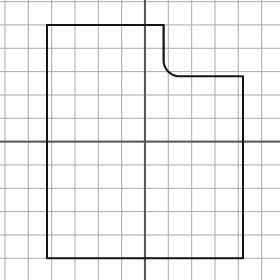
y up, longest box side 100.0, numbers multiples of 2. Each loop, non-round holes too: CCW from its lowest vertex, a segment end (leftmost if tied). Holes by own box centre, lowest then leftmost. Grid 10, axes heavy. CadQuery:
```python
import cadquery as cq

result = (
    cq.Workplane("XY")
    .moveTo(-42.0, -50.0)
    .lineTo(42.0, -50.0)
    .lineTo(42.0, 28.0)
    .lineTo(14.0, 28.0)
    .threePointArc((10.0, 30.0), (8.0, 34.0))
    .lineTo(8.0, 50.0)
    .lineTo(-42.0, 50.0)
    .close()
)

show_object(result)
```